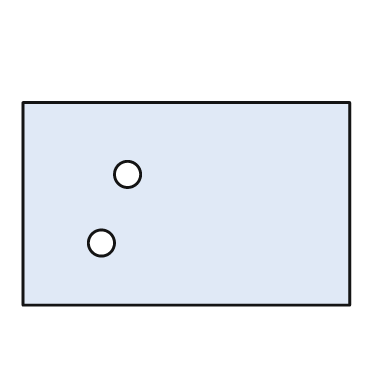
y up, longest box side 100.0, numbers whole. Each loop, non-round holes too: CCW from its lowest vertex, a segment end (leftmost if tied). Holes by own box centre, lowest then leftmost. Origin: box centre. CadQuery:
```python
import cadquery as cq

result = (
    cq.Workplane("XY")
    .moveTo(-50.0, -31.0)
    .lineTo(50.0, -31.0)
    .lineTo(50.0, 31.0)
    .lineTo(-50.0, 31.0)
    .close()
    .moveTo(-26.0, -12.0)
    .circle(4.0)
    .moveTo(-18.0, 9.0)
    .circle(4.0)
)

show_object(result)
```